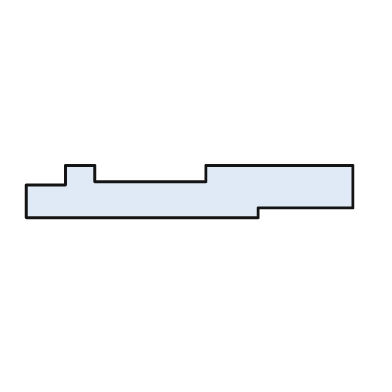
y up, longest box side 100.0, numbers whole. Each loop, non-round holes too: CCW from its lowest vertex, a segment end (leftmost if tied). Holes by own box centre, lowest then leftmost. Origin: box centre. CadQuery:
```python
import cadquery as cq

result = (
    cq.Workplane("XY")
    .moveTo(-50.0, -8.0)
    .lineTo(21.0, -8.0)
    .lineTo(21.0, -5.0)
    .lineTo(50.0, -5.0)
    .lineTo(50.0, 8.0)
    .lineTo(5.0, 8.0)
    .lineTo(5.0, 3.0)
    .lineTo(-29.0, 3.0)
    .lineTo(-29.0, 8.0)
    .lineTo(-38.0, 8.0)
    .lineTo(-38.0, 2.0)
    .lineTo(-50.0, 2.0)
    .close()
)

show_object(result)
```